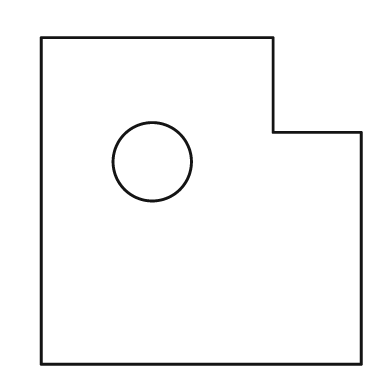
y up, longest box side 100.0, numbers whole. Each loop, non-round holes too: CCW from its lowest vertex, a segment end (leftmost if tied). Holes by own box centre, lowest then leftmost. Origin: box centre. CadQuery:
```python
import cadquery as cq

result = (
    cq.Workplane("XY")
    .moveTo(-49.0, -50.0)
    .lineTo(49.0, -50.0)
    .lineTo(49.0, 21.0)
    .lineTo(22.0, 21.0)
    .lineTo(22.0, 50.0)
    .lineTo(-49.0, 50.0)
    .close()
    .moveTo(-15.0, 12.0)
    .circle(12.0)
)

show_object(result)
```